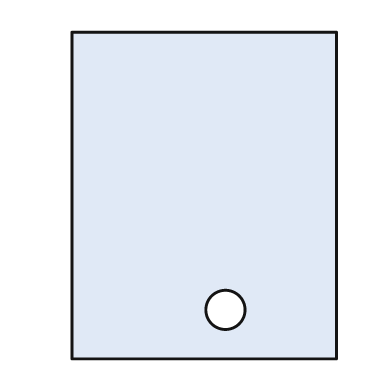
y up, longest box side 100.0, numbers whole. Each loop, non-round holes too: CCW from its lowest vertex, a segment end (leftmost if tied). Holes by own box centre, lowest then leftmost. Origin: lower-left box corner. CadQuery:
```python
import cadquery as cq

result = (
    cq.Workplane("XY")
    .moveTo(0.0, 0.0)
    .lineTo(81.0, 0.0)
    .lineTo(81.0, 100.0)
    .lineTo(0.0, 100.0)
    .close()
    .moveTo(47.0, 15.0)
    .circle(6.0)
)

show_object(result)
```